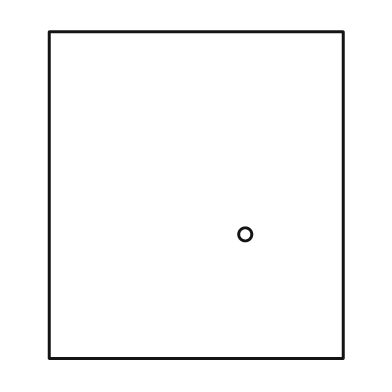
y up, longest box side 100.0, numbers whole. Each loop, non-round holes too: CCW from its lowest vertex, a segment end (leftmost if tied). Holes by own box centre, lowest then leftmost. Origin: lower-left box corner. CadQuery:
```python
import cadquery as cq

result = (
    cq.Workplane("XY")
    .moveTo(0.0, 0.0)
    .lineTo(90.0, 0.0)
    .lineTo(90.0, 100.0)
    .lineTo(0.0, 100.0)
    .close()
    .moveTo(60.0, 38.0)
    .circle(2.0)
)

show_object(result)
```